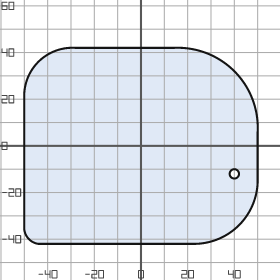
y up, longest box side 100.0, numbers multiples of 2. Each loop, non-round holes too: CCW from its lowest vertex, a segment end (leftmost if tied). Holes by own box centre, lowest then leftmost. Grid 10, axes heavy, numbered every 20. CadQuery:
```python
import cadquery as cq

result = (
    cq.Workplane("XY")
    .moveTo(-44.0, -42.0)
    .lineTo(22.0, -42.0)
    .threePointArc((42.0, -34.0), (50.0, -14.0))
    .lineTo(50.0, 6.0)
    .threePointArc((40.0, 32.0), (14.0, 42.0))
    .lineTo(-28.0, 42.0)
    .threePointArc((-44.0, 36.0), (-50.0, 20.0))
    .lineTo(-50.0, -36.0)
    .threePointArc((-48.0, -40.0), (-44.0, -42.0))
    .close()
    .moveTo(40.0, -12.0)
    .circle(2.0)
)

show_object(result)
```